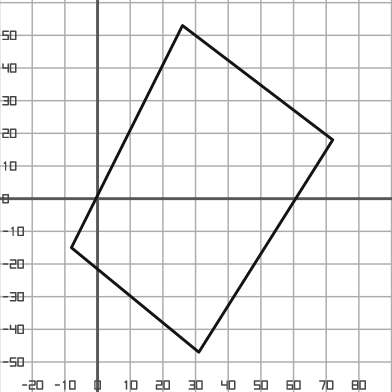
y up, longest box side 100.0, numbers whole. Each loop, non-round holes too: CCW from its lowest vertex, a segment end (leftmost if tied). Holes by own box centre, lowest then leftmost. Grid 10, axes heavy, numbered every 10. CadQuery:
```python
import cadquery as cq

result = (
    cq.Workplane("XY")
    .moveTo(31.0, -47.0)
    .lineTo(72.0, 18.0)
    .lineTo(26.0, 53.0)
    .lineTo(-8.0, -15.0)
    .close()
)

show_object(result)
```